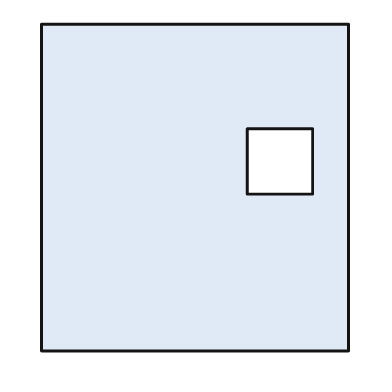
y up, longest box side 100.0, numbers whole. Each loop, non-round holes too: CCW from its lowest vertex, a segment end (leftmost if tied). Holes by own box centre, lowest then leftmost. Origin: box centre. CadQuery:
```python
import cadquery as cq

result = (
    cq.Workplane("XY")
    .moveTo(-47.0, -50.0)
    .lineTo(47.0, -50.0)
    .lineTo(47.0, 50.0)
    .lineTo(-47.0, 50.0)
    .close()
    .moveTo(16.0, -2.0)
    .lineTo(36.0, -2.0)
    .lineTo(36.0, 18.0)
    .lineTo(16.0, 18.0)
    .close()
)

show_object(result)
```